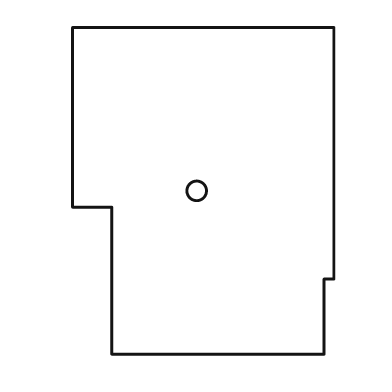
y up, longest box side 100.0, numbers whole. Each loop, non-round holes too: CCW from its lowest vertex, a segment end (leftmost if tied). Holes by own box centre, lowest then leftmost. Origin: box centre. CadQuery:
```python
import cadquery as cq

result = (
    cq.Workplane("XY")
    .moveTo(-28.0, -50.0)
    .lineTo(37.0, -50.0)
    .lineTo(37.0, -27.0)
    .lineTo(40.0, -27.0)
    .lineTo(40.0, 50.0)
    .lineTo(-40.0, 50.0)
    .lineTo(-40.0, -5.0)
    .lineTo(-28.0, -5.0)
    .close()
    .moveTo(-2.0, 0.0)
    .circle(3.0)
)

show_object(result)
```